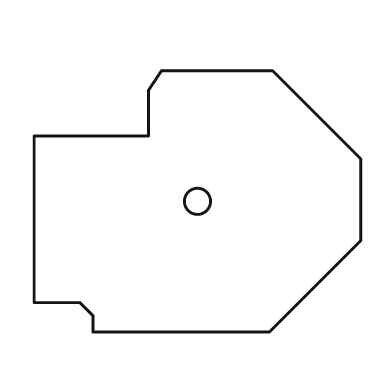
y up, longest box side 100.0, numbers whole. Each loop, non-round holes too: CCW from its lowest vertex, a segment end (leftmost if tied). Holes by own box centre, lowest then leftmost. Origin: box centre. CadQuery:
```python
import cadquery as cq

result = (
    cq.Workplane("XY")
    .moveTo(-32.0, -40.0)
    .lineTo(22.0, -40.0)
    .lineTo(50.0, -12.0)
    .lineTo(50.0, 13.0)
    .lineTo(23.0, 40.0)
    .lineTo(-11.0, 40.0)
    .lineTo(-15.0, 34.0)
    .lineTo(-15.0, 20.0)
    .lineTo(-50.0, 20.0)
    .lineTo(-50.0, -31.0)
    .lineTo(-36.0, -31.0)
    .lineTo(-32.0, -35.0)
    .close()
    .moveTo(0.0, 0.0)
    .circle(4.0)
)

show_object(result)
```